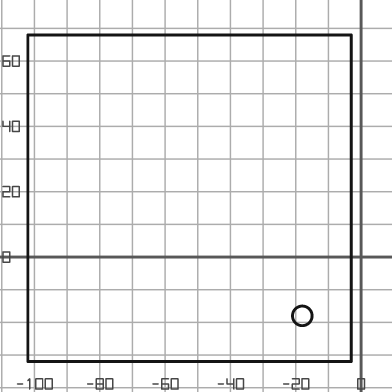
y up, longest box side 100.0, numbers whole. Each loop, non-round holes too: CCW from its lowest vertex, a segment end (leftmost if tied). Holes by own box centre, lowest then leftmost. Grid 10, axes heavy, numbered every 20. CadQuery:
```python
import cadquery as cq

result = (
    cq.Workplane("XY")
    .moveTo(-102.0, -32.0)
    .lineTo(-3.0, -32.0)
    .lineTo(-3.0, 68.0)
    .lineTo(-102.0, 68.0)
    .close()
    .moveTo(-18.0, -18.0)
    .circle(3.0)
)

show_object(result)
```